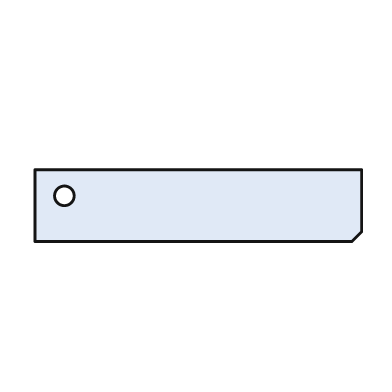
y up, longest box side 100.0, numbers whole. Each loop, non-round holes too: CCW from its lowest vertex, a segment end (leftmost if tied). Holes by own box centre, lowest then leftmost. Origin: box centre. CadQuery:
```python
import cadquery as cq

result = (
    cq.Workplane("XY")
    .moveTo(-50.0, -11.0)
    .lineTo(47.0, -11.0)
    .lineTo(50.0, -8.0)
    .lineTo(50.0, 11.0)
    .lineTo(-50.0, 11.0)
    .close()
    .moveTo(-41.0, 3.0)
    .circle(3.0)
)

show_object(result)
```